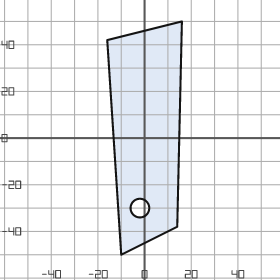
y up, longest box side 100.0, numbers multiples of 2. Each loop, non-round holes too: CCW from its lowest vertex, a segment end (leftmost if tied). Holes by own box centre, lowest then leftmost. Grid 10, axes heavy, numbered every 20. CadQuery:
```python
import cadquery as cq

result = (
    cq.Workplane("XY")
    .moveTo(-10.0, -50.0)
    .lineTo(14.0, -38.0)
    .lineTo(16.0, 50.0)
    .lineTo(-16.0, 42.0)
    .close()
    .moveTo(-2.0, -30.0)
    .circle(4.0)
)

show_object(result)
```